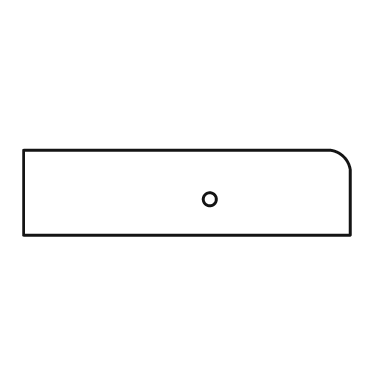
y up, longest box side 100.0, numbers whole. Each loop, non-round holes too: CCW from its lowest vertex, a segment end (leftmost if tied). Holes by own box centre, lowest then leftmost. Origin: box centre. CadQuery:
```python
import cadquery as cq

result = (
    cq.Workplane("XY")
    .moveTo(-50.0, -13.0)
    .lineTo(50.0, -13.0)
    .lineTo(50.0, 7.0)
    .threePointArc((48.0, 11.0), (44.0, 13.0))
    .lineTo(-50.0, 13.0)
    .close()
    .moveTo(7.0, -2.0)
    .circle(2.0)
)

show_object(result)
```